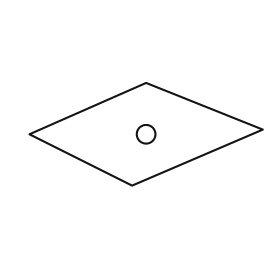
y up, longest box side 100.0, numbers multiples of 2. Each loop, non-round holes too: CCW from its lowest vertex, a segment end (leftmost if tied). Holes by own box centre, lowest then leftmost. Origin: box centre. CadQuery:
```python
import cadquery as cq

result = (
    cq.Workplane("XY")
    .moveTo(-6.0, -22.0)
    .lineTo(50.0, 2.0)
    .lineTo(0.0, 22.0)
    .lineTo(-50.0, 0.0)
    .close()
    .moveTo(0.0, 0.0)
    .circle(4.0)
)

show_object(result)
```